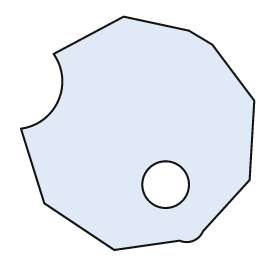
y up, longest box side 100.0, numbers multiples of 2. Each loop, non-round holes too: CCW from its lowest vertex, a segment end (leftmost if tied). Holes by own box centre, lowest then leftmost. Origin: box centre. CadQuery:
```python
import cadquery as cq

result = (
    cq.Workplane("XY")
    .moveTo(-10.0, -50.0)
    .lineTo(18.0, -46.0)
    .threePointArc((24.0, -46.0), (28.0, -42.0))
    .lineTo(48.0, -20.0)
    .lineTo(50.0, 14.0)
    .lineTo(32.0, 38.0)
    .lineTo(22.0, 44.0)
    .lineTo(-6.0, 50.0)
    .lineTo(-36.0, 34.0)
    .threePointArc((-34.0, 14.0), (-50.0, 2.0))
    .lineTo(-40.0, -30.0)
    .close()
    .moveTo(12.0, -22.0)
    .circle(10.0)
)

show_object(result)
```